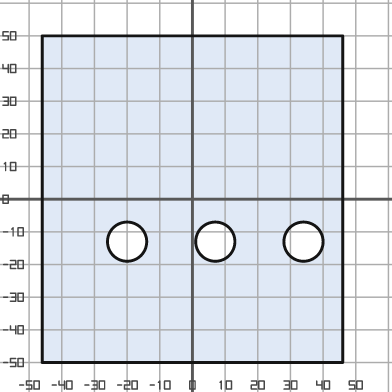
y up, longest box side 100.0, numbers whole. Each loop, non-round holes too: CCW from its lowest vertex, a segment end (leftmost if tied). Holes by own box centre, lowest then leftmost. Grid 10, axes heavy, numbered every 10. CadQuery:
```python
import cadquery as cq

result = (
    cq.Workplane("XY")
    .moveTo(-46.0, -50.0)
    .lineTo(46.0, -50.0)
    .lineTo(46.0, 50.0)
    .lineTo(-46.0, 50.0)
    .close()
    .moveTo(-20.0, -13.0)
    .circle(6.0)
    .moveTo(7.0, -13.0)
    .circle(6.0)
    .moveTo(34.0, -13.0)
    .circle(6.0)
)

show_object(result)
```